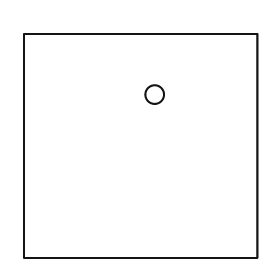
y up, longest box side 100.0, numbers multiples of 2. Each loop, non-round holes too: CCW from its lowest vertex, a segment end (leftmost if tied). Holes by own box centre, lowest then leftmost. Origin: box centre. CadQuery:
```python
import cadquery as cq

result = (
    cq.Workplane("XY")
    .moveTo(-50.0, -48.0)
    .lineTo(50.0, -48.0)
    .lineTo(50.0, 48.0)
    .lineTo(-50.0, 48.0)
    .close()
    .moveTo(6.0, 22.0)
    .circle(4.0)
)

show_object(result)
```